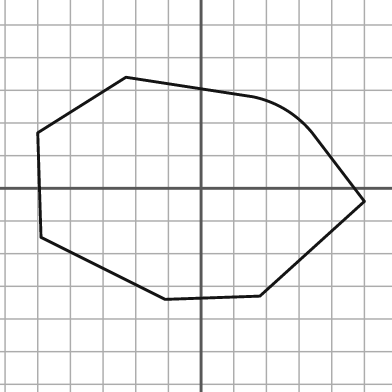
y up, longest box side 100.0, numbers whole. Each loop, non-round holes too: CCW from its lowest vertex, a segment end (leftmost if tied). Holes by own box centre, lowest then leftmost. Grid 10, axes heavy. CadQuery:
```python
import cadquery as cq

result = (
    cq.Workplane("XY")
    .moveTo(-11.0, -34.0)
    .lineTo(18.0, -33.0)
    .lineTo(50.0, -4.0)
    .lineTo(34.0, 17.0)
    .threePointArc((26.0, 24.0), (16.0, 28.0))
    .lineTo(-23.0, 34.0)
    .lineTo(-50.0, 17.0)
    .lineTo(-49.0, -15.0)
    .close()
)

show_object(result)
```